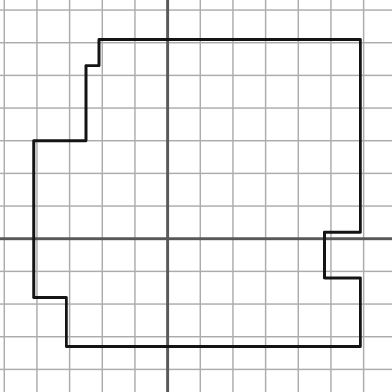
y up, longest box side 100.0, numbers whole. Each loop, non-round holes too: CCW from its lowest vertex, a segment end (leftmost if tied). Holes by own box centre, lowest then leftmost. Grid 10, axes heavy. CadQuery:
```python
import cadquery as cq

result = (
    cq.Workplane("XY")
    .moveTo(-31.0, -33.0)
    .lineTo(59.0, -33.0)
    .lineTo(59.0, -12.0)
    .lineTo(48.0, -12.0)
    .lineTo(48.0, 2.0)
    .lineTo(59.0, 2.0)
    .lineTo(59.0, 61.0)
    .lineTo(-21.0, 61.0)
    .lineTo(-21.0, 53.0)
    .lineTo(-25.0, 53.0)
    .lineTo(-25.0, 30.0)
    .lineTo(-41.0, 30.0)
    .lineTo(-41.0, -18.0)
    .lineTo(-31.0, -18.0)
    .close()
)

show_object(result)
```